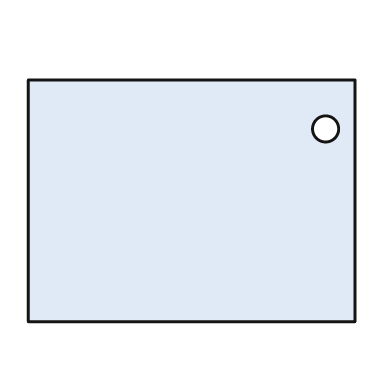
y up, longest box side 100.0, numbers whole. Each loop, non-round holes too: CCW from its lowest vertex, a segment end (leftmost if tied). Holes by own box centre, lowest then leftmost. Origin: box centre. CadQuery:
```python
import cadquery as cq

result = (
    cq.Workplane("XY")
    .moveTo(-50.0, -37.0)
    .lineTo(50.0, -37.0)
    .lineTo(50.0, 37.0)
    .lineTo(-50.0, 37.0)
    .close()
    .moveTo(41.0, 22.0)
    .circle(4.0)
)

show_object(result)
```